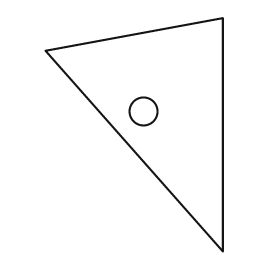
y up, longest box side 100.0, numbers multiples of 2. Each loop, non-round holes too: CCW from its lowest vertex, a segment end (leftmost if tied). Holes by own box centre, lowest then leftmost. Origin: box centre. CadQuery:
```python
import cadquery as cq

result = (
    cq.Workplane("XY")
    .moveTo(38.0, -50.0)
    .lineTo(38.0, 50.0)
    .lineTo(-38.0, 36.0)
    .close()
    .moveTo(4.0, 10.0)
    .circle(6.0)
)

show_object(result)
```